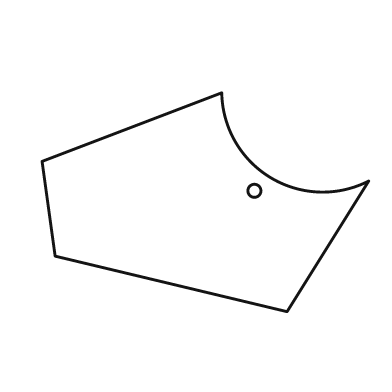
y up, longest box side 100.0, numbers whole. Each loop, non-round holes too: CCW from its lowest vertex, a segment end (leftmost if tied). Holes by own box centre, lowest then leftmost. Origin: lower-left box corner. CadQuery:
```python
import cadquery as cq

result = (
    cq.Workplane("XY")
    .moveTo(75.0, 0.0)
    .lineTo(100.0, 40.0)
    .threePointArc((70.0, 41.0), (55.0, 67.0))
    .lineTo(0.0, 46.0)
    .lineTo(4.0, 17.0)
    .close()
    .moveTo(65.0, 37.0)
    .circle(2.0)
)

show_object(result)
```